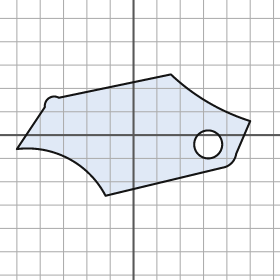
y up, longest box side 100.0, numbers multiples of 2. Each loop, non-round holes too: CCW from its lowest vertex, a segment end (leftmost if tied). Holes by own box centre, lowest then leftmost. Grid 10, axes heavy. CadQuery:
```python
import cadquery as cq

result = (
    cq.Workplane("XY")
    .moveTo(-12.0, -26.0)
    .lineTo(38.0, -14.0)
    .threePointArc((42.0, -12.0), (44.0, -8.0))
    .lineTo(50.0, 6.0)
    .threePointArc((32.0, 14.0), (16.0, 26.0))
    .lineTo(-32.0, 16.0)
    .threePointArc((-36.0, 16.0), (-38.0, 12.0))
    .lineTo(-50.0, -6.0)
    .threePointArc((-28.0, -10.0), (-12.0, -26.0))
    .close()
    .moveTo(32.0, -4.0)
    .circle(6.0)
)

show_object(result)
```